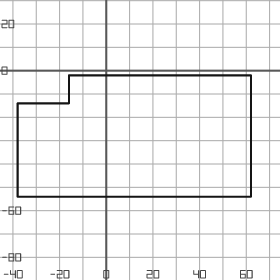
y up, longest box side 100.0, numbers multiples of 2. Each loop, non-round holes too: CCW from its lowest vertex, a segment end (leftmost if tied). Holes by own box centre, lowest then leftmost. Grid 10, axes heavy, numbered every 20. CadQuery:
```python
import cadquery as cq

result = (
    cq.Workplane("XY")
    .moveTo(-38.0, -54.0)
    .lineTo(62.0, -54.0)
    .lineTo(62.0, -2.0)
    .lineTo(-16.0, -2.0)
    .lineTo(-16.0, -14.0)
    .lineTo(-38.0, -14.0)
    .close()
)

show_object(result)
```